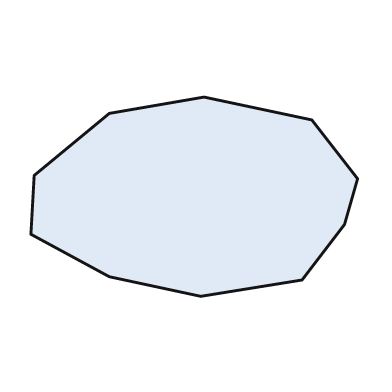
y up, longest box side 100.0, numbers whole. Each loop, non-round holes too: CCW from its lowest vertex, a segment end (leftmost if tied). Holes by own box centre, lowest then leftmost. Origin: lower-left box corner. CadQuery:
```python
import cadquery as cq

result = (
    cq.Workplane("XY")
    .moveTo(52.0, 0.0)
    .lineTo(83.0, 5.0)
    .lineTo(96.0, 22.0)
    .lineTo(100.0, 36.0)
    .lineTo(86.0, 54.0)
    .lineTo(53.0, 61.0)
    .lineTo(24.0, 56.0)
    .lineTo(1.0, 37.0)
    .lineTo(0.0, 19.0)
    .lineTo(24.0, 6.0)
    .close()
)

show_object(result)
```